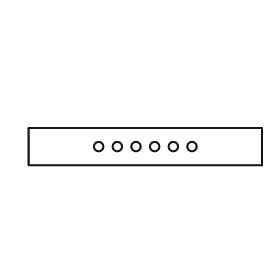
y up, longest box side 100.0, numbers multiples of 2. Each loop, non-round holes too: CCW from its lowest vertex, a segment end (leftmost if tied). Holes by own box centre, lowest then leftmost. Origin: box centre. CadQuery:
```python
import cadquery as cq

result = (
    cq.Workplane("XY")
    .moveTo(-50.0, -8.0)
    .lineTo(50.0, -8.0)
    .lineTo(50.0, 8.0)
    .lineTo(-50.0, 8.0)
    .close()
    .moveTo(-20.0, 0.0)
    .circle(2.0)
    .moveTo(-12.0, 0.0)
    .circle(2.0)
    .moveTo(-4.0, 0.0)
    .circle(2.0)
    .moveTo(4.0, 0.0)
    .circle(2.0)
    .moveTo(12.0, 0.0)
    .circle(2.0)
    .moveTo(20.0, 0.0)
    .circle(2.0)
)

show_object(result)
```